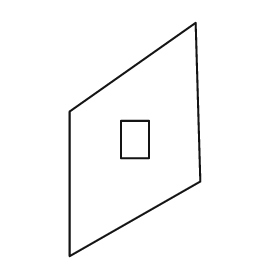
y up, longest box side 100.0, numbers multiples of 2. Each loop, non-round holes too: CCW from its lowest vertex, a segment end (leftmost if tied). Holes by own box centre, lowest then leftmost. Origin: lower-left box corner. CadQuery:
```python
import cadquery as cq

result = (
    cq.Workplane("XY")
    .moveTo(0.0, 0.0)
    .lineTo(56.0, 32.0)
    .lineTo(54.0, 100.0)
    .lineTo(0.0, 62.0)
    .close()
    .moveTo(22.0, 42.0)
    .lineTo(34.0, 42.0)
    .lineTo(34.0, 58.0)
    .lineTo(22.0, 58.0)
    .close()
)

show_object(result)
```